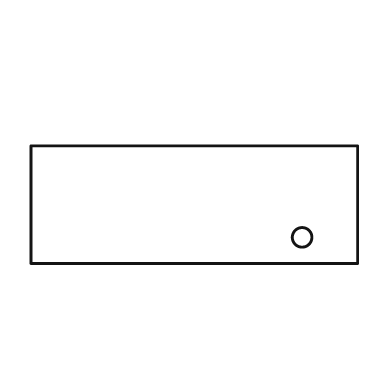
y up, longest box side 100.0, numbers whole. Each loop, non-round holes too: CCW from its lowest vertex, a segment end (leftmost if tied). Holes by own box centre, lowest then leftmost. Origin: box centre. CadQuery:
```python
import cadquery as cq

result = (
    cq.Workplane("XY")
    .moveTo(-50.0, -18.0)
    .lineTo(50.0, -18.0)
    .lineTo(50.0, 18.0)
    .lineTo(-50.0, 18.0)
    .close()
    .moveTo(33.0, -10.0)
    .circle(3.0)
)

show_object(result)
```